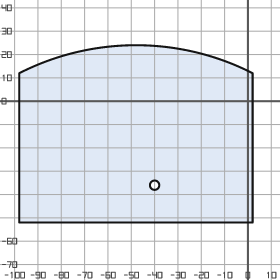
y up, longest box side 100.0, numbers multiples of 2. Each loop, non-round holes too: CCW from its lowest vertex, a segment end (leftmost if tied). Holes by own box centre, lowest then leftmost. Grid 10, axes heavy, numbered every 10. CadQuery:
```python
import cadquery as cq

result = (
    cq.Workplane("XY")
    .moveTo(-98.0, -52.0)
    .lineTo(2.0, -52.0)
    .lineTo(2.0, 12.0)
    .threePointArc((-48.0, 24.0), (-98.0, 12.0))
    .close()
    .moveTo(-40.0, -36.0)
    .circle(2.0)
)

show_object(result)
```